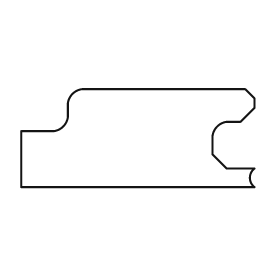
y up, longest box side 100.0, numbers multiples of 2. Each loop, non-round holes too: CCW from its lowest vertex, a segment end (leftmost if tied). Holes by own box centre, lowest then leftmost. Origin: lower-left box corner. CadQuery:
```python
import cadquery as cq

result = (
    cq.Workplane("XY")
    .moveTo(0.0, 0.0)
    .lineTo(100.0, 0.0)
    .threePointArc((98.0, 4.0), (100.0, 8.0))
    .lineTo(88.0, 8.0)
    .lineTo(82.0, 14.0)
    .lineTo(82.0, 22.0)
    .threePointArc((84.0, 26.0), (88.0, 28.0))
    .lineTo(94.0, 28.0)
    .lineTo(100.0, 34.0)
    .lineTo(100.0, 38.0)
    .lineTo(96.0, 42.0)
    .lineTo(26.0, 42.0)
    .threePointArc((22.0, 40.0), (20.0, 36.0))
    .lineTo(20.0, 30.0)
    .threePointArc((18.0, 26.0), (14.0, 24.0))
    .lineTo(0.0, 24.0)
    .close()
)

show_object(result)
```